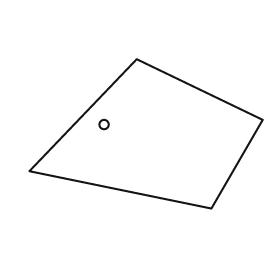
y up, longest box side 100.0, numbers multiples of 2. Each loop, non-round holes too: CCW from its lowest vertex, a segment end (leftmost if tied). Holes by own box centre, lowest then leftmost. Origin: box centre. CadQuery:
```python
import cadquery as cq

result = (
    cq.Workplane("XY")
    .moveTo(28.0, -32.0)
    .lineTo(50.0, 6.0)
    .lineTo(-4.0, 32.0)
    .lineTo(-50.0, -16.0)
    .close()
    .moveTo(-18.0, 4.0)
    .circle(2.0)
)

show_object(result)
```